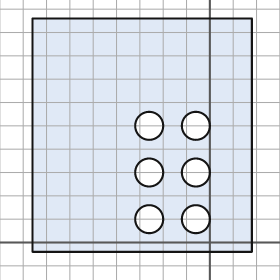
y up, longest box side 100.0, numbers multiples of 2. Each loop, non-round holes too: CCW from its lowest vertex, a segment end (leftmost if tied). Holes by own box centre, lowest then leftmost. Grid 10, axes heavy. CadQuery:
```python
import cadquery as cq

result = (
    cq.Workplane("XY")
    .moveTo(-76.0, -4.0)
    .lineTo(18.0, -4.0)
    .lineTo(18.0, 96.0)
    .lineTo(-76.0, 96.0)
    .close()
    .moveTo(-26.0, 10.0)
    .circle(6.0)
    .moveTo(-6.0, 10.0)
    .circle(6.0)
    .moveTo(-26.0, 30.0)
    .circle(6.0)
    .moveTo(-6.0, 30.0)
    .circle(6.0)
    .moveTo(-26.0, 50.0)
    .circle(6.0)
    .moveTo(-6.0, 50.0)
    .circle(6.0)
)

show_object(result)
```